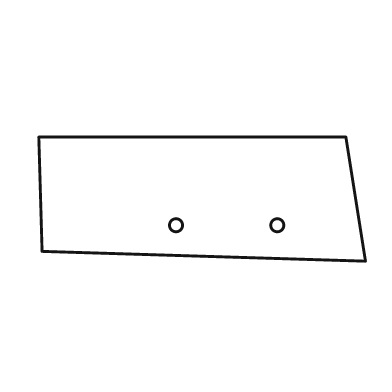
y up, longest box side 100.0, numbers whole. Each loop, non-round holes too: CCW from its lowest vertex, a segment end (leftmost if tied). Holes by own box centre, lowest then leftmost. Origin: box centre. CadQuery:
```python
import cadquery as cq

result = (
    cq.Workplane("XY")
    .moveTo(50.0, -19.0)
    .lineTo(44.0, 19.0)
    .lineTo(-50.0, 19.0)
    .lineTo(-49.0, -16.0)
    .close()
    .moveTo(-8.0, -8.0)
    .circle(2.0)
    .moveTo(23.0, -8.0)
    .circle(2.0)
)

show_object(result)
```